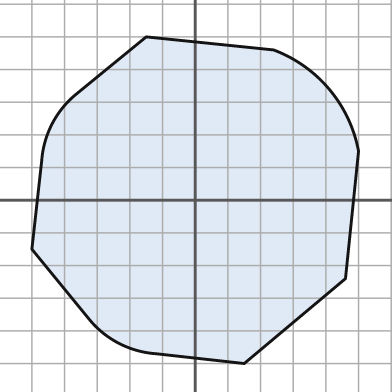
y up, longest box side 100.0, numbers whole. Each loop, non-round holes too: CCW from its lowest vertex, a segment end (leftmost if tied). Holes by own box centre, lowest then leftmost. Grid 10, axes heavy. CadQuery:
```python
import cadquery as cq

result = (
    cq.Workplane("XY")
    .moveTo(15.0, -50.0)
    .lineTo(46.0, -24.0)
    .lineTo(50.0, 15.0)
    .threePointArc((41.0, 34.0), (24.0, 46.0))
    .lineTo(-15.0, 50.0)
    .lineTo(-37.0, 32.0)
    .threePointArc((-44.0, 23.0), (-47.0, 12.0))
    .lineTo(-50.0, -15.0)
    .lineTo(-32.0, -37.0)
    .threePointArc((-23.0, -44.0), (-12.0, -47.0))
    .close()
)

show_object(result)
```